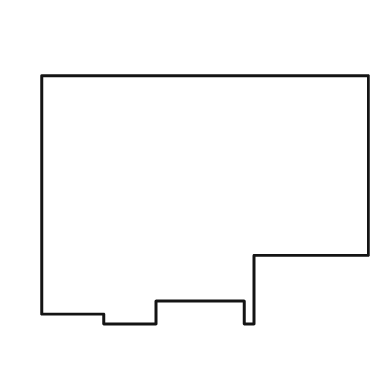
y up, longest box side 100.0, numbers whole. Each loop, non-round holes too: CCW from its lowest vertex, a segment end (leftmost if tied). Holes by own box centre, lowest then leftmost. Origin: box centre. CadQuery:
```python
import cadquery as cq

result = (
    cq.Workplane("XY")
    .moveTo(-31.0, -38.0)
    .lineTo(-15.0, -38.0)
    .lineTo(-15.0, -31.0)
    .lineTo(12.0, -31.0)
    .lineTo(12.0, -38.0)
    .lineTo(15.0, -38.0)
    .lineTo(15.0, -17.0)
    .lineTo(50.0, -17.0)
    .lineTo(50.0, 38.0)
    .lineTo(-50.0, 38.0)
    .lineTo(-50.0, -35.0)
    .lineTo(-31.0, -35.0)
    .close()
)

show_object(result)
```